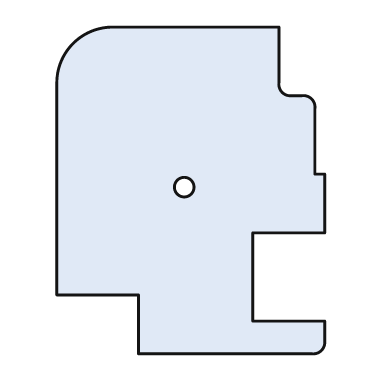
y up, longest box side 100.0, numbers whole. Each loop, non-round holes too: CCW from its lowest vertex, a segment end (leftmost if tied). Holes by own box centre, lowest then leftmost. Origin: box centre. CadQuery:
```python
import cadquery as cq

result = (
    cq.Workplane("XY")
    .moveTo(-16.0, -50.0)
    .lineTo(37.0, -50.0)
    .threePointArc((40.0, -49.0), (41.0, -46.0))
    .lineTo(41.0, -40.0)
    .lineTo(19.0, -40.0)
    .lineTo(19.0, -13.0)
    .lineTo(41.0, -13.0)
    .lineTo(41.0, 5.0)
    .lineTo(38.0, 5.0)
    .lineTo(38.0, 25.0)
    .threePointArc((37.0, 28.0), (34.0, 29.0))
    .lineTo(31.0, 29.0)
    .threePointArc((28.0, 30.0), (27.0, 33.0))
    .lineTo(27.0, 50.0)
    .lineTo(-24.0, 50.0)
    .threePointArc((-36.0, 45.0), (-41.0, 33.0))
    .lineTo(-41.0, -32.0)
    .lineTo(-16.0, -32.0)
    .close()
    .moveTo(-2.0, 1.0)
    .circle(3.0)
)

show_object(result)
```